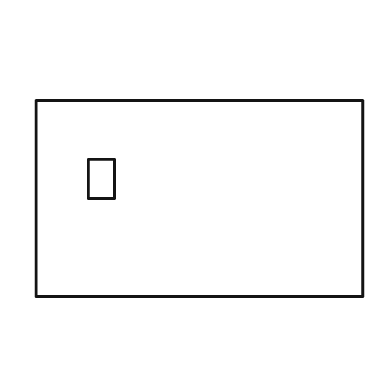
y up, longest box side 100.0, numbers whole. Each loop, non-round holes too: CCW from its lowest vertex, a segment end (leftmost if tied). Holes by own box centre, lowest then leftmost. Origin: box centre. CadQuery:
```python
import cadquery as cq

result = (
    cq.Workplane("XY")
    .moveTo(-50.0, -30.0)
    .lineTo(50.0, -30.0)
    .lineTo(50.0, 30.0)
    .lineTo(-50.0, 30.0)
    .close()
    .moveTo(-34.0, 0.0)
    .lineTo(-26.0, 0.0)
    .lineTo(-26.0, 12.0)
    .lineTo(-34.0, 12.0)
    .close()
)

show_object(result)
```